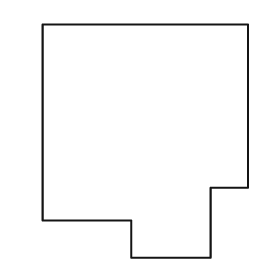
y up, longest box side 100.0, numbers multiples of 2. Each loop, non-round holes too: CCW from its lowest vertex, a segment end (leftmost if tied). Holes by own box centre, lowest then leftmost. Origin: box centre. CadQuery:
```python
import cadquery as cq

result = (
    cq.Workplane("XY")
    .moveTo(-6.0, -50.0)
    .lineTo(28.0, -50.0)
    .lineTo(28.0, -20.0)
    .lineTo(44.0, -20.0)
    .lineTo(44.0, 50.0)
    .lineTo(-44.0, 50.0)
    .lineTo(-44.0, -34.0)
    .lineTo(-6.0, -34.0)
    .close()
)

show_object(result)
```